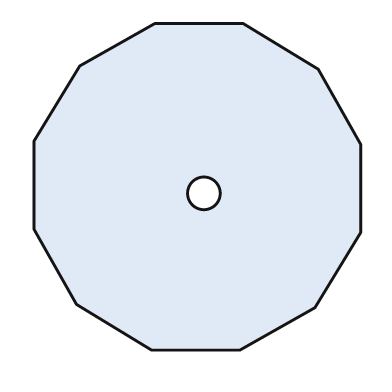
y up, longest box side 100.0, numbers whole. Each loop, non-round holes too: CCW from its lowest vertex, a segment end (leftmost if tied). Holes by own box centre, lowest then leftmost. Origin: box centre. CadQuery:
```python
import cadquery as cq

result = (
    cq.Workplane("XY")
    .moveTo(-14.0, -50.0)
    .lineTo(13.0, -50.0)
    .lineTo(36.0, -37.0)
    .lineTo(50.0, -14.0)
    .lineTo(50.0, 13.0)
    .lineTo(37.0, 36.0)
    .lineTo(14.0, 50.0)
    .lineTo(-13.0, 50.0)
    .lineTo(-36.0, 37.0)
    .lineTo(-50.0, 14.0)
    .lineTo(-50.0, -13.0)
    .lineTo(-37.0, -36.0)
    .close()
    .moveTo(2.0, -2.0)
    .circle(5.0)
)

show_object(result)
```